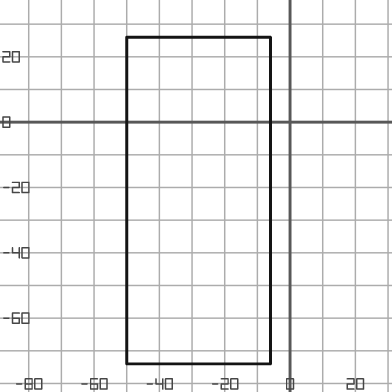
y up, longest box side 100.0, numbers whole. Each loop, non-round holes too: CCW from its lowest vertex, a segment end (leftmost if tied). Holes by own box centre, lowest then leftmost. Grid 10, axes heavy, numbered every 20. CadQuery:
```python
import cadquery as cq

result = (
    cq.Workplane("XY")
    .moveTo(-50.0, -74.0)
    .lineTo(-6.0, -74.0)
    .lineTo(-6.0, 26.0)
    .lineTo(-50.0, 26.0)
    .close()
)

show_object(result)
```